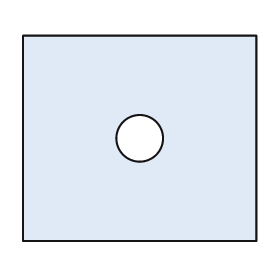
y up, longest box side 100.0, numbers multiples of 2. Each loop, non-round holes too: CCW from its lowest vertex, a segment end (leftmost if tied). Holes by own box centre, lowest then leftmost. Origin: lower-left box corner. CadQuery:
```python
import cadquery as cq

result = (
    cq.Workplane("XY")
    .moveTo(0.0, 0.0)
    .lineTo(100.0, 0.0)
    .lineTo(100.0, 88.0)
    .lineTo(0.0, 88.0)
    .close()
    .moveTo(50.0, 44.0)
    .circle(10.0)
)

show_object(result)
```